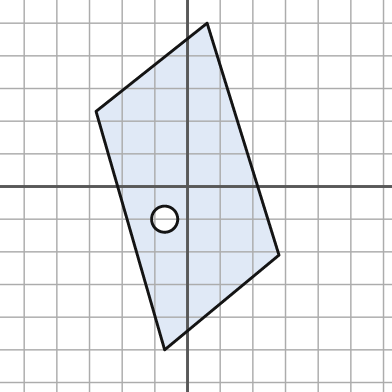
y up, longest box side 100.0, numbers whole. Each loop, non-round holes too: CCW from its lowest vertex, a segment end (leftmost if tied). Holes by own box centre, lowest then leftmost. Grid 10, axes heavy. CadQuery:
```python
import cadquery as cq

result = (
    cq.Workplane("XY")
    .moveTo(-7.0, -50.0)
    .lineTo(28.0, -21.0)
    .lineTo(6.0, 50.0)
    .lineTo(-28.0, 23.0)
    .close()
    .moveTo(-7.0, -10.0)
    .circle(4.0)
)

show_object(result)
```